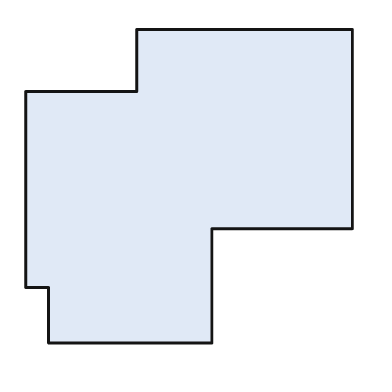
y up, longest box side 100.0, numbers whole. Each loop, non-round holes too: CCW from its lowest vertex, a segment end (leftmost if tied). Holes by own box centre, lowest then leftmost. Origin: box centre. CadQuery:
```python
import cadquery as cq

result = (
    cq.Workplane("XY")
    .moveTo(-43.0, -48.0)
    .lineTo(7.0, -48.0)
    .lineTo(7.0, -13.0)
    .lineTo(50.0, -13.0)
    .lineTo(50.0, 48.0)
    .lineTo(-16.0, 48.0)
    .lineTo(-16.0, 29.0)
    .lineTo(-50.0, 29.0)
    .lineTo(-50.0, -31.0)
    .lineTo(-43.0, -31.0)
    .close()
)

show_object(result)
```